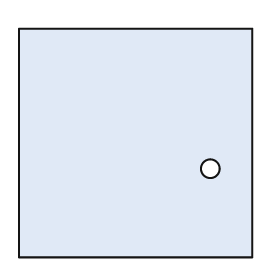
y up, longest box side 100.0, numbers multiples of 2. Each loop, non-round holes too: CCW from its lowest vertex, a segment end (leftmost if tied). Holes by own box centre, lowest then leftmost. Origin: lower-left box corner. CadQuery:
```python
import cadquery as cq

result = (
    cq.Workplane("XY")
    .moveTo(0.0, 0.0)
    .lineTo(100.0, 0.0)
    .lineTo(100.0, 98.0)
    .lineTo(0.0, 98.0)
    .close()
    .moveTo(82.0, 38.0)
    .circle(4.0)
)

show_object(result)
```